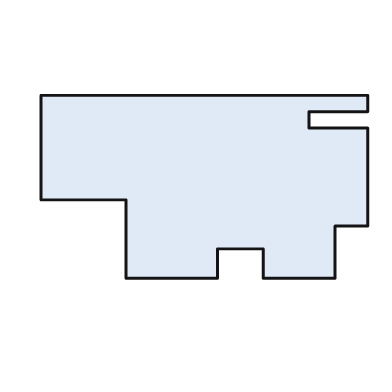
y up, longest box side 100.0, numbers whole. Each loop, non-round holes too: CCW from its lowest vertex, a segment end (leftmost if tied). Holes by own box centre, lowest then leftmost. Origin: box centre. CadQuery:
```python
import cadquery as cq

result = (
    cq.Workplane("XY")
    .moveTo(-24.0, -28.0)
    .lineTo(4.0, -28.0)
    .lineTo(4.0, -19.0)
    .lineTo(18.0, -19.0)
    .lineTo(18.0, -28.0)
    .lineTo(40.0, -28.0)
    .lineTo(40.0, -12.0)
    .lineTo(50.0, -12.0)
    .lineTo(50.0, 18.0)
    .lineTo(32.0, 18.0)
    .lineTo(32.0, 23.0)
    .lineTo(50.0, 23.0)
    .lineTo(50.0, 28.0)
    .lineTo(-50.0, 28.0)
    .lineTo(-50.0, -4.0)
    .lineTo(-24.0, -4.0)
    .close()
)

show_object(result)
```